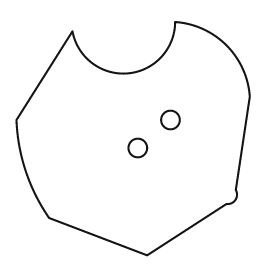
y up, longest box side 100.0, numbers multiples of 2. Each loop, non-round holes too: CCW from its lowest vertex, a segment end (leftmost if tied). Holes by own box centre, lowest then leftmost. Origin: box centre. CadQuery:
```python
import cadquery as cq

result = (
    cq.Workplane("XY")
    .moveTo(6.0, -50.0)
    .lineTo(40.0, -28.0)
    .threePointArc((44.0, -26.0), (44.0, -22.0))
    .lineTo(50.0, 18.0)
    .threePointArc((40.0, 40.0), (18.0, 50.0))
    .threePointArc((-2.0, 28.0), (-26.0, 46.0))
    .lineTo(-50.0, 8.0)
    .threePointArc((-46.0, -14.0), (-36.0, -34.0))
    .close()
    .moveTo(2.0, -4.0)
    .circle(4.0)
    .moveTo(16.0, 8.0)
    .circle(4.0)
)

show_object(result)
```